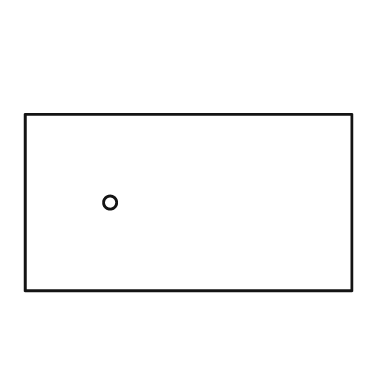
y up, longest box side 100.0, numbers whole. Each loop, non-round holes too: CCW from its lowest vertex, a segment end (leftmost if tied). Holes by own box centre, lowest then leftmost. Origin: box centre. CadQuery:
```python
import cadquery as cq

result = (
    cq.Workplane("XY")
    .moveTo(-50.0, -27.0)
    .lineTo(50.0, -27.0)
    .lineTo(50.0, 27.0)
    .lineTo(-50.0, 27.0)
    .close()
    .moveTo(-24.0, 0.0)
    .circle(2.0)
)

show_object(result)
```